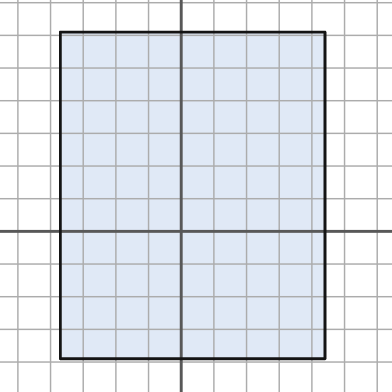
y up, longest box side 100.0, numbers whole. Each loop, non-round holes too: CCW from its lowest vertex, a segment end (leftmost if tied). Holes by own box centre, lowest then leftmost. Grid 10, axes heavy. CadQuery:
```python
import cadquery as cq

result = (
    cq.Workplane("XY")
    .moveTo(-37.0, -39.0)
    .lineTo(44.0, -39.0)
    .lineTo(44.0, 61.0)
    .lineTo(-37.0, 61.0)
    .close()
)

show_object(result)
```